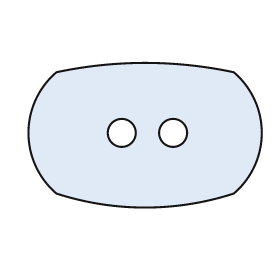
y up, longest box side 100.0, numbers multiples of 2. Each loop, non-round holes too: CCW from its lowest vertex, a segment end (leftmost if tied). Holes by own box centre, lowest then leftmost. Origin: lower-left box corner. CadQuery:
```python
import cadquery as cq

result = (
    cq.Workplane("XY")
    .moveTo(12.0, 6.0)
    .threePointArc((50.0, 0.0), (88.0, 6.0))
    .threePointArc((100.0, 32.0), (88.0, 58.0))
    .threePointArc((50.0, 62.0), (12.0, 58.0))
    .threePointArc((0.0, 32.0), (12.0, 6.0))
    .close()
    .moveTo(40.0, 32.0)
    .circle(6.0)
    .moveTo(62.0, 32.0)
    .circle(6.0)
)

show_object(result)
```